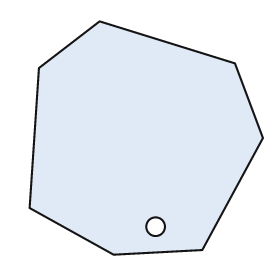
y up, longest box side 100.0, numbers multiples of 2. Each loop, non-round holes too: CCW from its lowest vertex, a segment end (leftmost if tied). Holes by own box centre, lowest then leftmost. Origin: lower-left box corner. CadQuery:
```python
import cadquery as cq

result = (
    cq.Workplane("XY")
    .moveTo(36.0, 0.0)
    .lineTo(74.0, 2.0)
    .lineTo(100.0, 50.0)
    .lineTo(88.0, 82.0)
    .lineTo(30.0, 100.0)
    .lineTo(4.0, 80.0)
    .lineTo(0.0, 20.0)
    .close()
    .moveTo(54.0, 12.0)
    .circle(4.0)
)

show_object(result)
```